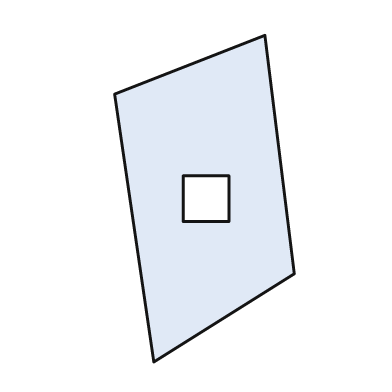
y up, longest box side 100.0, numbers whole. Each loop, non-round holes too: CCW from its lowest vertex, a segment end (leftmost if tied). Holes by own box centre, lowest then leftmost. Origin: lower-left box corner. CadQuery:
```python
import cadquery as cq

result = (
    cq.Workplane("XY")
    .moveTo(12.0, 0.0)
    .lineTo(55.0, 27.0)
    .lineTo(46.0, 100.0)
    .lineTo(0.0, 82.0)
    .close()
    .moveTo(21.0, 43.0)
    .lineTo(35.0, 43.0)
    .lineTo(35.0, 57.0)
    .lineTo(21.0, 57.0)
    .close()
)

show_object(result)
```